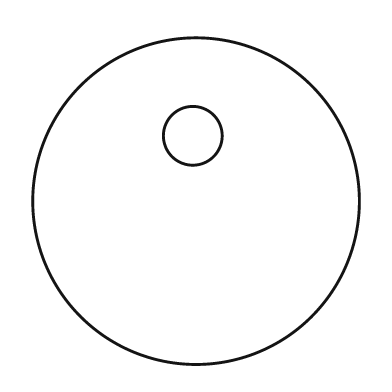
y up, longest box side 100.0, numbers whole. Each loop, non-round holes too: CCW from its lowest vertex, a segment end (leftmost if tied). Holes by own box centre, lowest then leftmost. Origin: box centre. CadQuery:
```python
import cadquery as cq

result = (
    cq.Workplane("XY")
    .moveTo(0.0, 0.0)
    .circle(50.0)
    .moveTo(-1.0, 20.0)
    .circle(9.0)
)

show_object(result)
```